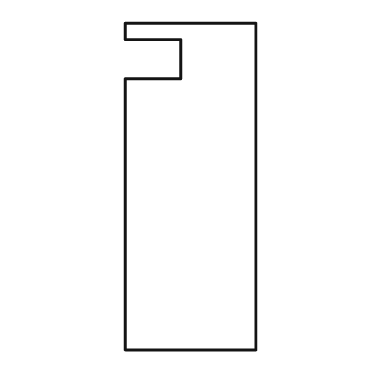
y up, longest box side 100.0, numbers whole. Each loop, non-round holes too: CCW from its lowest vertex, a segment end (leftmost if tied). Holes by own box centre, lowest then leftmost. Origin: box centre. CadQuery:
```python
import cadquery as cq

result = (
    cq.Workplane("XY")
    .moveTo(-20.0, -50.0)
    .lineTo(20.0, -50.0)
    .lineTo(20.0, 50.0)
    .lineTo(-20.0, 50.0)
    .lineTo(-20.0, 45.0)
    .lineTo(-3.0, 45.0)
    .lineTo(-3.0, 33.0)
    .lineTo(-20.0, 33.0)
    .close()
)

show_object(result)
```